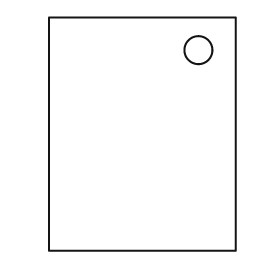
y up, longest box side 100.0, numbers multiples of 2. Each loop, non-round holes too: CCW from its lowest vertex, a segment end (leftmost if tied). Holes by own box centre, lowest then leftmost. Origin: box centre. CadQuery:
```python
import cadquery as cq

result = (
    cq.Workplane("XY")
    .moveTo(-40.0, -50.0)
    .lineTo(40.0, -50.0)
    .lineTo(40.0, 50.0)
    .lineTo(-40.0, 50.0)
    .close()
    .moveTo(24.0, 36.0)
    .circle(6.0)
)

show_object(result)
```